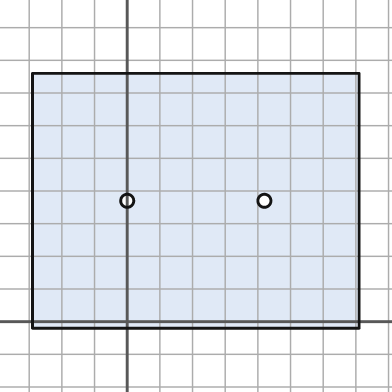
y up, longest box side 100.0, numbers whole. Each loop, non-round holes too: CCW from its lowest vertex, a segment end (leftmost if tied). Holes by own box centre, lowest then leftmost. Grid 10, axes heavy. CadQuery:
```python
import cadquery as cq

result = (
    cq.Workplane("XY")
    .moveTo(-29.0, -2.0)
    .lineTo(71.0, -2.0)
    .lineTo(71.0, 76.0)
    .lineTo(-29.0, 76.0)
    .close()
    .moveTo(0.0, 37.0)
    .circle(2.0)
    .moveTo(42.0, 37.0)
    .circle(2.0)
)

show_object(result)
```